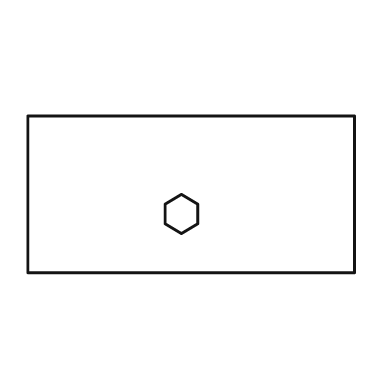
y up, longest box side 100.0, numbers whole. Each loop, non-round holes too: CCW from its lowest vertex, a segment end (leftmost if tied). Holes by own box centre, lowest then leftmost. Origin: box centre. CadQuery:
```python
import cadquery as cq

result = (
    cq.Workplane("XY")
    .moveTo(-50.0, -24.0)
    .lineTo(50.0, -24.0)
    .lineTo(50.0, 24.0)
    .lineTo(-50.0, 24.0)
    .close()
    .moveTo(-3.0, -12.0)
    .lineTo(2.0, -9.0)
    .lineTo(2.0, -3.0)
    .lineTo(-3.0, 0.0)
    .lineTo(-8.0, -3.0)
    .lineTo(-8.0, -9.0)
    .close()
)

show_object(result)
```